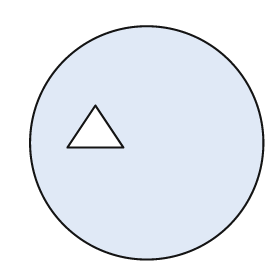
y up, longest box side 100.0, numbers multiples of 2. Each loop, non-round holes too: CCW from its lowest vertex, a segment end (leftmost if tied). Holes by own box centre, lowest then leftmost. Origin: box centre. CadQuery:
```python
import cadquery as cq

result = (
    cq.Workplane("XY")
    .moveTo(0.0, 0.0)
    .circle(50.0)
    .moveTo(-34.0, -2.0)
    .lineTo(-10.0, -2.0)
    .lineTo(-22.0, 16.0)
    .close()
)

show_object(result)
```